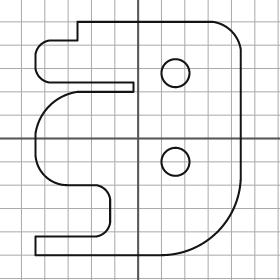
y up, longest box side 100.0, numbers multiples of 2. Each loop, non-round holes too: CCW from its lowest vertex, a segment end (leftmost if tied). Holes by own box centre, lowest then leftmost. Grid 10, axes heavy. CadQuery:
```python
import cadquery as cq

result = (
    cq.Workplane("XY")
    .moveTo(-44.0, -50.0)
    .lineTo(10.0, -50.0)
    .threePointArc((34.0, -40.0), (44.0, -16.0))
    .lineTo(44.0, 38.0)
    .threePointArc((40.0, 46.0), (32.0, 50.0))
    .lineTo(-26.0, 50.0)
    .lineTo(-26.0, 42.0)
    .lineTo(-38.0, 42.0)
    .threePointArc((-42.0, 40.0), (-44.0, 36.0))
    .lineTo(-44.0, 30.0)
    .threePointArc((-42.0, 26.0), (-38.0, 24.0))
    .lineTo(-2.0, 24.0)
    .lineTo(-2.0, 20.0)
    .lineTo(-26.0, 20.0)
    .threePointArc((-38.0, 14.0), (-44.0, 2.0))
    .lineTo(-44.0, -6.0)
    .threePointArc((-40.0, -16.0), (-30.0, -20.0))
    .lineTo(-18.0, -20.0)
    .threePointArc((-14.0, -22.0), (-12.0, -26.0))
    .lineTo(-12.0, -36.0)
    .threePointArc((-14.0, -40.0), (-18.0, -42.0))
    .lineTo(-44.0, -42.0)
    .close()
    .moveTo(16.0, -10.0)
    .circle(6.0)
    .moveTo(16.0, 28.0)
    .circle(6.0)
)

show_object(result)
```